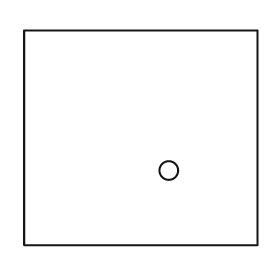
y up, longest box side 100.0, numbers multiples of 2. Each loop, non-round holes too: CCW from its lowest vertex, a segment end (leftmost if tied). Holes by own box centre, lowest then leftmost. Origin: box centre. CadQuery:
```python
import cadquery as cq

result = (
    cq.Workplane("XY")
    .moveTo(-50.0, -46.0)
    .lineTo(50.0, -46.0)
    .lineTo(50.0, 46.0)
    .lineTo(-50.0, 46.0)
    .close()
    .moveTo(12.0, -14.0)
    .circle(4.0)
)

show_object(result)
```